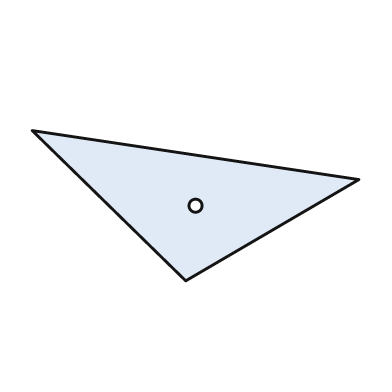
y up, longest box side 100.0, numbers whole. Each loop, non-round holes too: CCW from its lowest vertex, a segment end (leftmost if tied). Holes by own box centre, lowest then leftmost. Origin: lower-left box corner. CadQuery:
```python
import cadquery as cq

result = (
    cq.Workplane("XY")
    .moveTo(47.0, 0.0)
    .lineTo(100.0, 31.0)
    .lineTo(0.0, 46.0)
    .close()
    .moveTo(50.0, 23.0)
    .circle(2.0)
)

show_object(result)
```